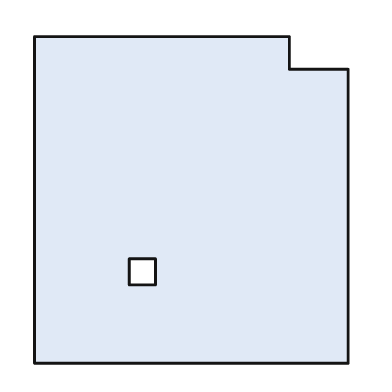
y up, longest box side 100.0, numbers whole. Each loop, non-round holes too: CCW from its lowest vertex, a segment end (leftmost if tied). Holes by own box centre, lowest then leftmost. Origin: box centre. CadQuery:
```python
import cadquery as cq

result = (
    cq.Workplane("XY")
    .moveTo(-48.0, -50.0)
    .lineTo(48.0, -50.0)
    .lineTo(48.0, 40.0)
    .lineTo(30.0, 40.0)
    .lineTo(30.0, 50.0)
    .lineTo(-48.0, 50.0)
    .close()
    .moveTo(-19.0, -26.0)
    .lineTo(-11.0, -26.0)
    .lineTo(-11.0, -18.0)
    .lineTo(-19.0, -18.0)
    .close()
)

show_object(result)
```